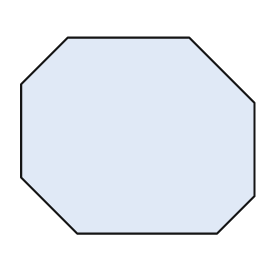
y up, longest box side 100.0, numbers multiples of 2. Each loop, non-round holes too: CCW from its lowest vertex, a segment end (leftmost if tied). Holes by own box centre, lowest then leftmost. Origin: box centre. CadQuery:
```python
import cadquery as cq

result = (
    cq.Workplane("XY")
    .moveTo(-26.0, -42.0)
    .lineTo(34.0, -42.0)
    .lineTo(50.0, -26.0)
    .lineTo(50.0, 14.0)
    .lineTo(22.0, 42.0)
    .lineTo(-30.0, 42.0)
    .lineTo(-50.0, 22.0)
    .lineTo(-50.0, -18.0)
    .close()
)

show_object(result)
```